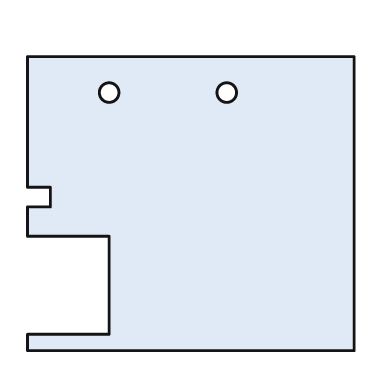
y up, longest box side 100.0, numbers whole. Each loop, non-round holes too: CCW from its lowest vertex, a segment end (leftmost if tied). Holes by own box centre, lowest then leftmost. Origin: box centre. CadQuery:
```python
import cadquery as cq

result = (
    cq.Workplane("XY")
    .moveTo(-50.0, -45.0)
    .lineTo(50.0, -45.0)
    .lineTo(50.0, 45.0)
    .lineTo(-50.0, 45.0)
    .lineTo(-50.0, 5.0)
    .lineTo(-43.0, 5.0)
    .lineTo(-43.0, -1.0)
    .lineTo(-50.0, -1.0)
    .lineTo(-50.0, -10.0)
    .lineTo(-25.0, -10.0)
    .lineTo(-25.0, -40.0)
    .lineTo(-50.0, -40.0)
    .close()
    .moveTo(-25.0, 34.0)
    .circle(3.0)
    .moveTo(11.0, 34.0)
    .circle(3.0)
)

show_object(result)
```